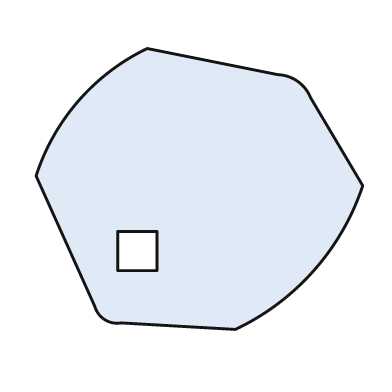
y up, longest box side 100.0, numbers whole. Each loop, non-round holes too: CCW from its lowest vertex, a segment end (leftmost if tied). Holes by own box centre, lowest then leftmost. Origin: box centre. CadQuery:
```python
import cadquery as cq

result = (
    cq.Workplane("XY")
    .moveTo(11.0, -43.0)
    .threePointArc((35.0, -25.0), (50.0, 1.0))
    .lineTo(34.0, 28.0)
    .threePointArc((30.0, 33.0), (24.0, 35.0))
    .lineTo(-16.0, 43.0)
    .threePointArc((-37.0, 27.0), (-50.0, 4.0))
    .lineTo(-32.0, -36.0)
    .threePointArc((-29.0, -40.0), (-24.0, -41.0))
    .close()
    .moveTo(-25.0, -25.0)
    .lineTo(-13.0, -25.0)
    .lineTo(-13.0, -13.0)
    .lineTo(-25.0, -13.0)
    .close()
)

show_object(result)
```